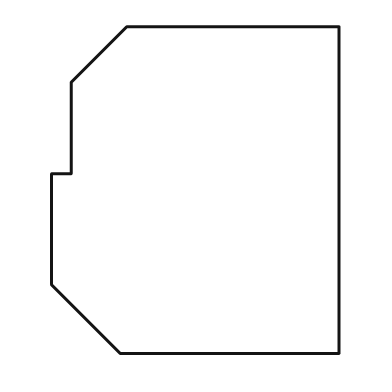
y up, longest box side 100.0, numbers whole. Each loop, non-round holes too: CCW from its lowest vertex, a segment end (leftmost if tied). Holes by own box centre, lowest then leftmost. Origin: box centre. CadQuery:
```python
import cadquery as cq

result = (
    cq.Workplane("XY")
    .moveTo(-23.0, -50.0)
    .lineTo(44.0, -50.0)
    .lineTo(44.0, 50.0)
    .lineTo(-21.0, 50.0)
    .lineTo(-38.0, 33.0)
    .lineTo(-38.0, 5.0)
    .lineTo(-44.0, 5.0)
    .lineTo(-44.0, -29.0)
    .close()
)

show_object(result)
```